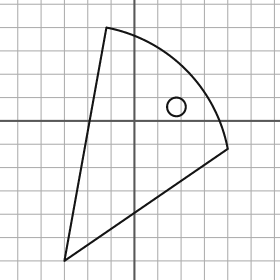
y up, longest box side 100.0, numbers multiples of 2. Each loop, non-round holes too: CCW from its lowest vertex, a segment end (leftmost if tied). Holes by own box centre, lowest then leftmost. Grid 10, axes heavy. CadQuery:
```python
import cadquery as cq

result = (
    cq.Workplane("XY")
    .moveTo(-30.0, -60.0)
    .lineTo(40.0, -12.0)
    .threePointArc((22.0, 22.0), (-12.0, 40.0))
    .close()
    .moveTo(18.0, 6.0)
    .circle(4.0)
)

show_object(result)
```